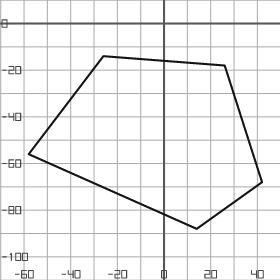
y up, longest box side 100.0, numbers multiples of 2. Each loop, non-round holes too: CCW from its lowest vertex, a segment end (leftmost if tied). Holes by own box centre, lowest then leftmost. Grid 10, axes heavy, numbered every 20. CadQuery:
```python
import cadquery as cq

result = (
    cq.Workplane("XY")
    .moveTo(14.0, -88.0)
    .lineTo(42.0, -68.0)
    .lineTo(26.0, -18.0)
    .lineTo(-26.0, -14.0)
    .lineTo(-58.0, -56.0)
    .close()
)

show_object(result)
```